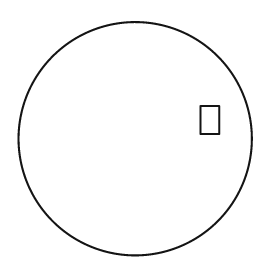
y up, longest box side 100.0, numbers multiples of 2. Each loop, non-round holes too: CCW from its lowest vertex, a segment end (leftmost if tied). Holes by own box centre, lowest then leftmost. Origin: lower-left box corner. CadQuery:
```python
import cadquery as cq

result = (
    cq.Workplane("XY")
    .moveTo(50.0, 50.0)
    .circle(50.0)
    .moveTo(78.0, 52.0)
    .lineTo(86.0, 52.0)
    .lineTo(86.0, 64.0)
    .lineTo(78.0, 64.0)
    .close()
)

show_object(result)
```